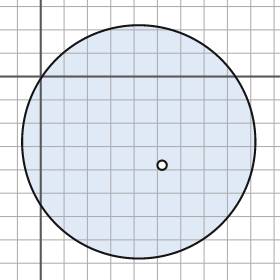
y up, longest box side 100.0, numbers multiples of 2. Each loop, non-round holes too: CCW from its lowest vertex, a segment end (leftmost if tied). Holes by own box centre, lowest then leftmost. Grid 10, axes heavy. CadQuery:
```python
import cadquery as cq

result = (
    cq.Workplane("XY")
    .moveTo(42.0, -28.0)
    .circle(50.0)
    .moveTo(52.0, -38.0)
    .circle(2.0)
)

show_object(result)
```